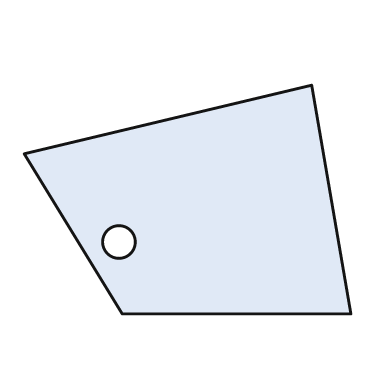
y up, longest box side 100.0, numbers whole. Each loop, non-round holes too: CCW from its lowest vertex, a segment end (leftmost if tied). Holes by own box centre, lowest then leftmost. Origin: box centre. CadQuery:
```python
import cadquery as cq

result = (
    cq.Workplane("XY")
    .moveTo(-20.0, -35.0)
    .lineTo(50.0, -35.0)
    .lineTo(38.0, 35.0)
    .lineTo(-50.0, 14.0)
    .close()
    .moveTo(-21.0, -13.0)
    .circle(5.0)
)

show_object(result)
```